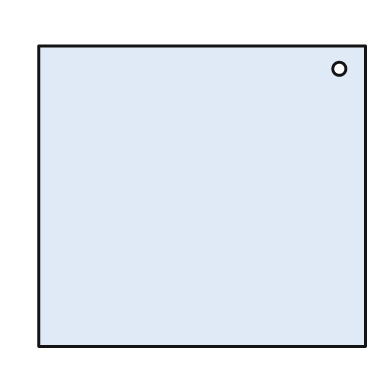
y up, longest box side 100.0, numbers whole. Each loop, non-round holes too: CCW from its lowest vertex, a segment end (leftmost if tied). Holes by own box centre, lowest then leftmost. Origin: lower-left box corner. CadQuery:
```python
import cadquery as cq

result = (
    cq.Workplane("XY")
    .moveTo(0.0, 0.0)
    .lineTo(100.0, 0.0)
    .lineTo(100.0, 92.0)
    .lineTo(0.0, 92.0)
    .close()
    .moveTo(92.0, 85.0)
    .circle(2.0)
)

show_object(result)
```